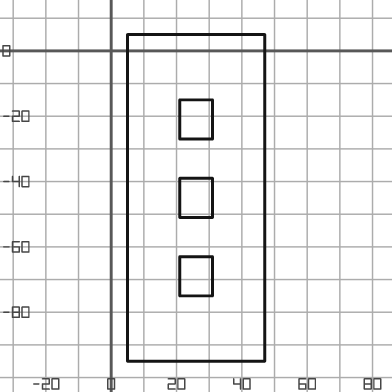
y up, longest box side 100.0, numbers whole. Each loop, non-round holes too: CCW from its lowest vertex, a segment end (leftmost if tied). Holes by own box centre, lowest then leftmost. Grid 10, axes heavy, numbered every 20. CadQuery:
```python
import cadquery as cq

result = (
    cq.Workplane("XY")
    .moveTo(5.0, -95.0)
    .lineTo(47.0, -95.0)
    .lineTo(47.0, 5.0)
    .lineTo(5.0, 5.0)
    .close()
    .moveTo(21.0, -75.0)
    .lineTo(31.0, -75.0)
    .lineTo(31.0, -63.0)
    .lineTo(21.0, -63.0)
    .close()
    .moveTo(21.0, -51.0)
    .lineTo(31.0, -51.0)
    .lineTo(31.0, -39.0)
    .lineTo(21.0, -39.0)
    .close()
    .moveTo(21.0, -27.0)
    .lineTo(31.0, -27.0)
    .lineTo(31.0, -15.0)
    .lineTo(21.0, -15.0)
    .close()
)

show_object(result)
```